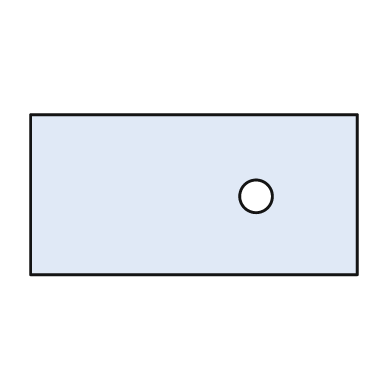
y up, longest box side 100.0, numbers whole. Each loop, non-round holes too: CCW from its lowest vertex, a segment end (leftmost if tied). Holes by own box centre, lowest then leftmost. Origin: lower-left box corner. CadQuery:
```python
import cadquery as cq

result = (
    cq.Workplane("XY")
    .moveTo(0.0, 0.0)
    .lineTo(100.0, 0.0)
    .lineTo(100.0, 49.0)
    .lineTo(0.0, 49.0)
    .close()
    .moveTo(69.0, 24.0)
    .circle(5.0)
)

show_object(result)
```